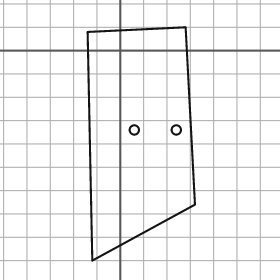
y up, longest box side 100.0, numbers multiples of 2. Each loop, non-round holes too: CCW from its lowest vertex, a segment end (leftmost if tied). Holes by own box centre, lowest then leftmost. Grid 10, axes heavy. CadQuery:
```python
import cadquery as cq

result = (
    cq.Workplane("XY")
    .moveTo(-12.0, -90.0)
    .lineTo(32.0, -66.0)
    .lineTo(28.0, 10.0)
    .lineTo(-14.0, 8.0)
    .close()
    .moveTo(6.0, -34.0)
    .circle(2.0)
    .moveTo(24.0, -34.0)
    .circle(2.0)
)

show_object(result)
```